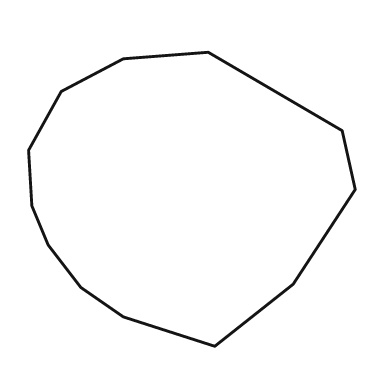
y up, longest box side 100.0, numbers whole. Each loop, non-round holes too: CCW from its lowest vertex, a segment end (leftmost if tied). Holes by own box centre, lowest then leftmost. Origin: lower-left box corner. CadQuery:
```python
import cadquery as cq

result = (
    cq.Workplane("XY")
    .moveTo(57.0, 0.0)
    .lineTo(81.0, 19.0)
    .lineTo(100.0, 48.0)
    .lineTo(96.0, 66.0)
    .lineTo(55.0, 90.0)
    .lineTo(29.0, 88.0)
    .lineTo(10.0, 78.0)
    .lineTo(0.0, 60.0)
    .lineTo(1.0, 43.0)
    .lineTo(6.0, 31.0)
    .lineTo(16.0, 18.0)
    .lineTo(29.0, 9.0)
    .close()
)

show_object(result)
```